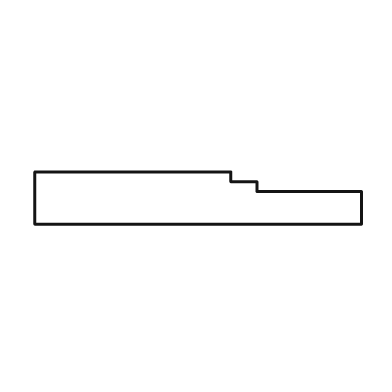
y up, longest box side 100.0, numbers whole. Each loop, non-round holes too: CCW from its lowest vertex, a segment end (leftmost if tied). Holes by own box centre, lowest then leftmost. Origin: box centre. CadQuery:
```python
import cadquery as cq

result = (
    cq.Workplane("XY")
    .moveTo(-50.0, -8.0)
    .lineTo(50.0, -8.0)
    .lineTo(50.0, 2.0)
    .lineTo(18.0, 2.0)
    .lineTo(18.0, 5.0)
    .lineTo(10.0, 5.0)
    .lineTo(10.0, 8.0)
    .lineTo(-50.0, 8.0)
    .close()
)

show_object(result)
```